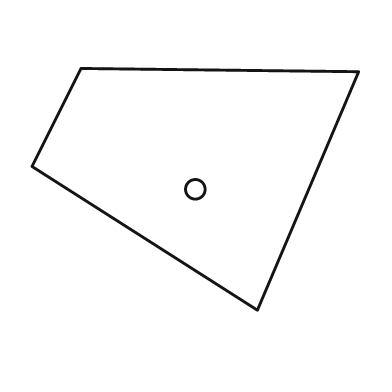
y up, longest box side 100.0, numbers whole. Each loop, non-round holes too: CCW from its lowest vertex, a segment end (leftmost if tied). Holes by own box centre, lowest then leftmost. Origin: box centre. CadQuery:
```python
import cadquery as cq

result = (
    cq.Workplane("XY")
    .moveTo(19.0, -37.0)
    .lineTo(50.0, 36.0)
    .lineTo(-35.0, 37.0)
    .lineTo(-50.0, 7.0)
    .close()
    .moveTo(0.0, 0.0)
    .circle(3.0)
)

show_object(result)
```